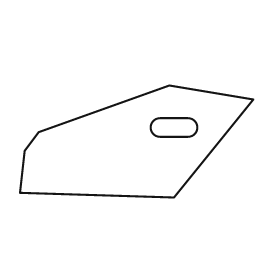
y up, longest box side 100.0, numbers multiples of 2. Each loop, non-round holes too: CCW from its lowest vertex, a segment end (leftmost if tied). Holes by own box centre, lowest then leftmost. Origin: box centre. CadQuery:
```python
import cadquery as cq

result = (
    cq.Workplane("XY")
    .moveTo(16.0, -24.0)
    .lineTo(50.0, 18.0)
    .lineTo(14.0, 24.0)
    .lineTo(-42.0, 4.0)
    .lineTo(-48.0, -4.0)
    .lineTo(-50.0, -22.0)
    .close()
    .moveTo(10.0, 2.0)
    .lineTo(22.0, 2.0)
    .threePointArc((26.0, 6.0), (22.0, 10.0))
    .lineTo(10.0, 10.0)
    .threePointArc((6.0, 6.0), (10.0, 2.0))
    .close()
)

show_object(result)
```